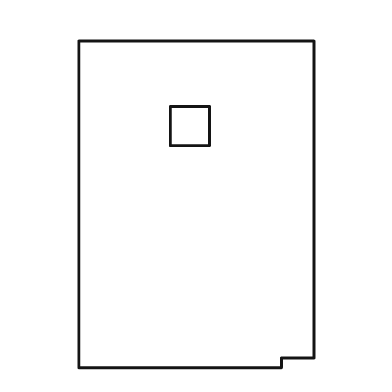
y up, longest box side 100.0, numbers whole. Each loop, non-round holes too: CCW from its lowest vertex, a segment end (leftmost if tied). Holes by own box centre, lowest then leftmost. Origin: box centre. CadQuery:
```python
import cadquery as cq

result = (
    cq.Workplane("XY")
    .moveTo(-36.0, -50.0)
    .lineTo(26.0, -50.0)
    .lineTo(26.0, -47.0)
    .lineTo(36.0, -47.0)
    .lineTo(36.0, 50.0)
    .lineTo(-36.0, 50.0)
    .close()
    .moveTo(-8.0, 18.0)
    .lineTo(4.0, 18.0)
    .lineTo(4.0, 30.0)
    .lineTo(-8.0, 30.0)
    .close()
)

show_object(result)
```